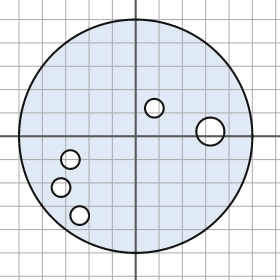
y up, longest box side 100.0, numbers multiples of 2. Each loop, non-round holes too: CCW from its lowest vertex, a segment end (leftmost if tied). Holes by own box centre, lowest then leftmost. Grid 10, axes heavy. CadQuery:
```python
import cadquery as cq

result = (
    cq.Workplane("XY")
    .moveTo(0.0, 0.0)
    .circle(50.0)
    .moveTo(-24.0, -34.0)
    .circle(4.0)
    .moveTo(-32.0, -22.0)
    .circle(4.0)
    .moveTo(-28.0, -10.0)
    .circle(4.0)
    .moveTo(32.0, 2.0)
    .circle(6.0)
    .moveTo(8.0, 12.0)
    .circle(4.0)
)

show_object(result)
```